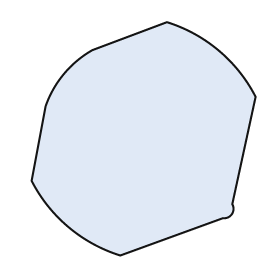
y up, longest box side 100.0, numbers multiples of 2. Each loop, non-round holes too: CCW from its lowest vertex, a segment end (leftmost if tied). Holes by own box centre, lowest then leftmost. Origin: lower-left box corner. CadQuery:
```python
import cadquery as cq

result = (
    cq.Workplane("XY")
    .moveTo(38.0, 0.0)
    .lineTo(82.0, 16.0)
    .threePointArc((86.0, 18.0), (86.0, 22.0))
    .lineTo(96.0, 68.0)
    .threePointArc((80.0, 88.0), (58.0, 100.0))
    .lineTo(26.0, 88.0)
    .threePointArc((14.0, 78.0), (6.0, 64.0))
    .lineTo(0.0, 32.0)
    .threePointArc((16.0, 12.0), (38.0, 0.0))
    .close()
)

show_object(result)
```